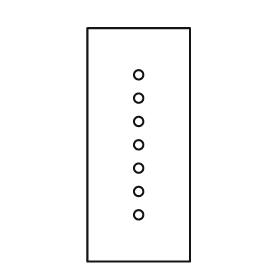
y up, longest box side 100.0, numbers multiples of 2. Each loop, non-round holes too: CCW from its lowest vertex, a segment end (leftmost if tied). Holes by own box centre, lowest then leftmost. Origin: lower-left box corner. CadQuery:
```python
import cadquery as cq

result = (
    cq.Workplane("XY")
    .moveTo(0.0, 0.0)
    .lineTo(44.0, 0.0)
    .lineTo(44.0, 100.0)
    .lineTo(0.0, 100.0)
    .close()
    .moveTo(22.0, 20.0)
    .circle(2.0)
    .moveTo(22.0, 30.0)
    .circle(2.0)
    .moveTo(22.0, 40.0)
    .circle(2.0)
    .moveTo(22.0, 50.0)
    .circle(2.0)
    .moveTo(22.0, 60.0)
    .circle(2.0)
    .moveTo(22.0, 70.0)
    .circle(2.0)
    .moveTo(22.0, 80.0)
    .circle(2.0)
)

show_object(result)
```